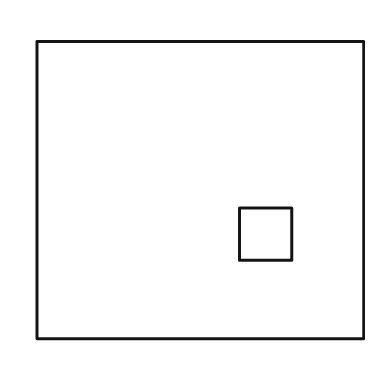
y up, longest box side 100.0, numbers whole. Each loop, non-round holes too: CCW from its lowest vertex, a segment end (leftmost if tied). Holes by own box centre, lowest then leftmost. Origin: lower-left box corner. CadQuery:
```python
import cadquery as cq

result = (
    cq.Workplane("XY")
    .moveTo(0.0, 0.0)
    .lineTo(100.0, 0.0)
    .lineTo(100.0, 91.0)
    .lineTo(0.0, 91.0)
    .close()
    .moveTo(62.0, 24.0)
    .lineTo(78.0, 24.0)
    .lineTo(78.0, 40.0)
    .lineTo(62.0, 40.0)
    .close()
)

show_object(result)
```